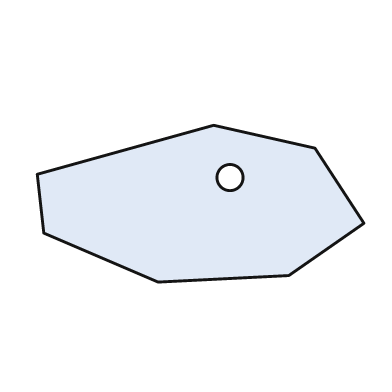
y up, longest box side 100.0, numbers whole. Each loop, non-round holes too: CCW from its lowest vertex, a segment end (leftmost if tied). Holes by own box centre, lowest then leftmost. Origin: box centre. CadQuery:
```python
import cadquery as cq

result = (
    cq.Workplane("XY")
    .moveTo(-13.0, -24.0)
    .lineTo(27.0, -22.0)
    .lineTo(50.0, -6.0)
    .lineTo(35.0, 17.0)
    .lineTo(4.0, 24.0)
    .lineTo(-50.0, 9.0)
    .lineTo(-48.0, -9.0)
    .close()
    .moveTo(9.0, 8.0)
    .circle(4.0)
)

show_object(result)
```